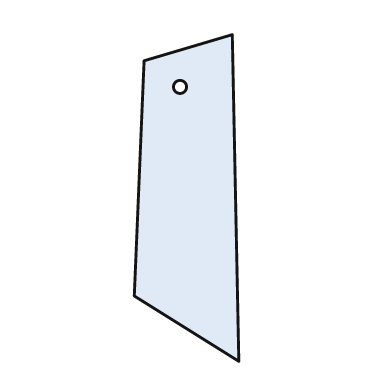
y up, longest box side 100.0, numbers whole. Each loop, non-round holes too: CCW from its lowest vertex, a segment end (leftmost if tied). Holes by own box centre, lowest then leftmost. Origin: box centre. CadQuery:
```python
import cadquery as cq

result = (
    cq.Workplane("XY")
    .moveTo(16.0, -50.0)
    .lineTo(14.0, 50.0)
    .lineTo(-13.0, 42.0)
    .lineTo(-16.0, -30.0)
    .close()
    .moveTo(-2.0, 34.0)
    .circle(2.0)
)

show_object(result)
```